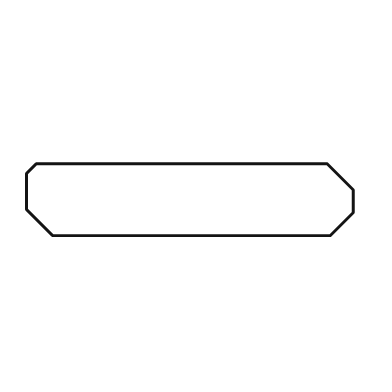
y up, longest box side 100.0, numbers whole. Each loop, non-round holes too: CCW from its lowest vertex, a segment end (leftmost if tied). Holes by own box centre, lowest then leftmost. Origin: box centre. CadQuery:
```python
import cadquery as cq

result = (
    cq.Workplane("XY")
    .moveTo(-42.0, -11.0)
    .lineTo(43.0, -11.0)
    .lineTo(50.0, -4.0)
    .lineTo(50.0, 3.0)
    .lineTo(42.0, 11.0)
    .lineTo(-47.0, 11.0)
    .lineTo(-50.0, 8.0)
    .lineTo(-50.0, -3.0)
    .close()
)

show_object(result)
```